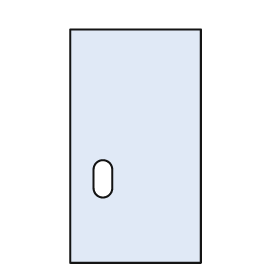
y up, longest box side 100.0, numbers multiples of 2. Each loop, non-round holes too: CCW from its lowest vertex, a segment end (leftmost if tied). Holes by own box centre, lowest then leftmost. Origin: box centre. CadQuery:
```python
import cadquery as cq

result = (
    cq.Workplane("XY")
    .moveTo(-28.0, -50.0)
    .lineTo(28.0, -50.0)
    .lineTo(28.0, 50.0)
    .lineTo(-28.0, 50.0)
    .close()
    .moveTo(-18.0, -18.0)
    .threePointArc((-14.0, -22.0), (-10.0, -18.0))
    .lineTo(-10.0, -10.0)
    .threePointArc((-14.0, -6.0), (-18.0, -10.0))
    .close()
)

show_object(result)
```